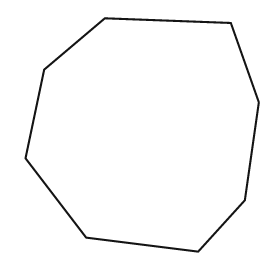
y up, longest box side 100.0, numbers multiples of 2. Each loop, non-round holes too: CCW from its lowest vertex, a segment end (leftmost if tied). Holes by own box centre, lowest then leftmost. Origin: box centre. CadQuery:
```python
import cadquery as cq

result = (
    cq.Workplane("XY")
    .moveTo(24.0, -50.0)
    .lineTo(44.0, -28.0)
    .lineTo(50.0, 14.0)
    .lineTo(38.0, 48.0)
    .lineTo(-16.0, 50.0)
    .lineTo(-42.0, 28.0)
    .lineTo(-50.0, -10.0)
    .lineTo(-24.0, -44.0)
    .close()
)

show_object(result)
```